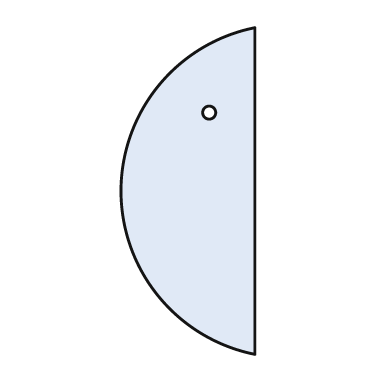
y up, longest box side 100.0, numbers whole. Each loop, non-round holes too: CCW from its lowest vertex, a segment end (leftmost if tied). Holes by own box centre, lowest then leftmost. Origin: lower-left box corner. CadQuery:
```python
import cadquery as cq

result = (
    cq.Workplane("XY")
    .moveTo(41.0, 0.0)
    .lineTo(41.0, 100.0)
    .threePointArc((0.0, 50.0), (41.0, 0.0))
    .close()
    .moveTo(27.0, 74.0)
    .circle(2.0)
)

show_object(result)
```